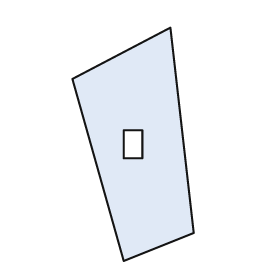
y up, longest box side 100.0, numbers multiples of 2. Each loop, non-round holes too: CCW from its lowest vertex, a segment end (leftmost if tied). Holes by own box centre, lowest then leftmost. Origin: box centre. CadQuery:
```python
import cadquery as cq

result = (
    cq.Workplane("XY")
    .moveTo(-4.0, -50.0)
    .lineTo(26.0, -38.0)
    .lineTo(16.0, 50.0)
    .lineTo(-26.0, 28.0)
    .close()
    .moveTo(-4.0, -6.0)
    .lineTo(4.0, -6.0)
    .lineTo(4.0, 6.0)
    .lineTo(-4.0, 6.0)
    .close()
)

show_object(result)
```